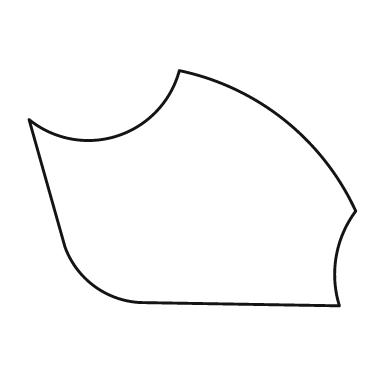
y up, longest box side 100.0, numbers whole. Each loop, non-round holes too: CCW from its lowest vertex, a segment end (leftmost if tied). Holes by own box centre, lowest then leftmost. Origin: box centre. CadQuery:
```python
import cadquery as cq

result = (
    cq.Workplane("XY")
    .moveTo(45.0, -36.0)
    .threePointArc((44.0, -21.0), (50.0, -7.0))
    .threePointArc((28.0, 21.0), (-4.0, 36.0))
    .threePointArc((-23.0, 16.0), (-50.0, 21.0))
    .lineTo(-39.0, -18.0)
    .threePointArc((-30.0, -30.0), (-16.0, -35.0))
    .close()
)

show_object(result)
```